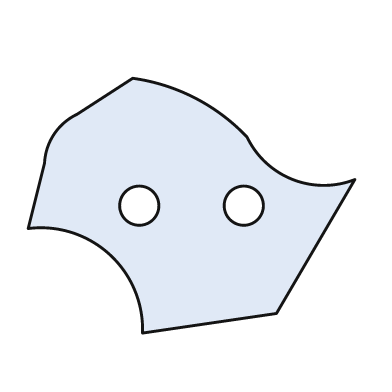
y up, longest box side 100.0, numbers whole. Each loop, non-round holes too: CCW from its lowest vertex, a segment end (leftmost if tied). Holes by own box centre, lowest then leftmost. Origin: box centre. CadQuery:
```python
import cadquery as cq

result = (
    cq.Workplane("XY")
    .moveTo(-15.0, -39.0)
    .lineTo(26.0, -33.0)
    .lineTo(50.0, 8.0)
    .threePointArc((31.0, 8.0), (17.0, 21.0))
    .threePointArc((1.0, 33.0), (-18.0, 39.0))
    .lineTo(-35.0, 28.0)
    .threePointArc((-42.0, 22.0), (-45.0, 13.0))
    .lineTo(-50.0, -7.0)
    .threePointArc((-25.0, -15.0), (-15.0, -39.0))
    .close()
    .moveTo(-16.0, 0.0)
    .circle(6.0)
    .moveTo(16.0, 0.0)
    .circle(6.0)
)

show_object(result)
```